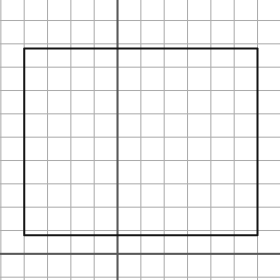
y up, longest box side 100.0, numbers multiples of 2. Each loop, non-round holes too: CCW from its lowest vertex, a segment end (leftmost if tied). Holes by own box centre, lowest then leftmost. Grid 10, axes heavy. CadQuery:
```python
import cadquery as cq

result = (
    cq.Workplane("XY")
    .moveTo(-40.0, 8.0)
    .lineTo(60.0, 8.0)
    .lineTo(60.0, 88.0)
    .lineTo(-40.0, 88.0)
    .close()
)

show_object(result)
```